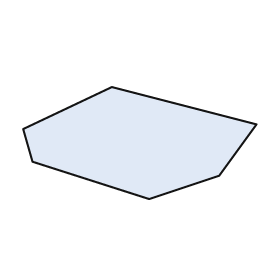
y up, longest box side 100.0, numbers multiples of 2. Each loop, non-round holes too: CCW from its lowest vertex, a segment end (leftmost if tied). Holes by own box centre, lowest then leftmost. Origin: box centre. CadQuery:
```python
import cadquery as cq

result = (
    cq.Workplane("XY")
    .moveTo(4.0, -24.0)
    .lineTo(34.0, -14.0)
    .lineTo(50.0, 8.0)
    .lineTo(-12.0, 24.0)
    .lineTo(-50.0, 6.0)
    .lineTo(-46.0, -8.0)
    .close()
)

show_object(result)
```